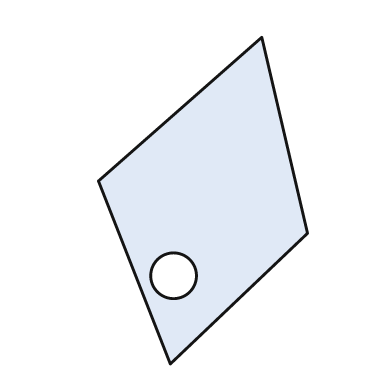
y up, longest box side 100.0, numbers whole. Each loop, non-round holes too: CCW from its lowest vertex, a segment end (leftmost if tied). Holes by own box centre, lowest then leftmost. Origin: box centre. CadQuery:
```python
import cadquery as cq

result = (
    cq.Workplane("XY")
    .moveTo(-10.0, -50.0)
    .lineTo(32.0, -10.0)
    .lineTo(18.0, 50.0)
    .lineTo(-32.0, 6.0)
    .close()
    .moveTo(-9.0, -23.0)
    .circle(7.0)
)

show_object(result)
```